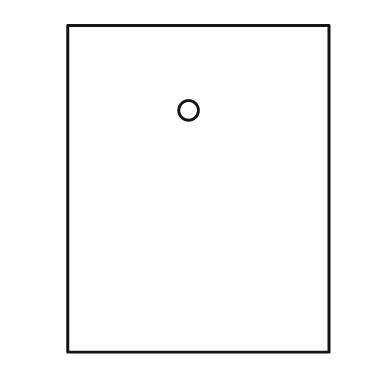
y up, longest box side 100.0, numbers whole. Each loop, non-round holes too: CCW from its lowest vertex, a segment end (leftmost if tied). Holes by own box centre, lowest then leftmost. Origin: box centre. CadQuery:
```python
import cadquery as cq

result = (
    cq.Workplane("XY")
    .moveTo(-40.0, -50.0)
    .lineTo(40.0, -50.0)
    .lineTo(40.0, 50.0)
    .lineTo(-40.0, 50.0)
    .close()
    .moveTo(-3.0, 24.0)
    .circle(3.0)
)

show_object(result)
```